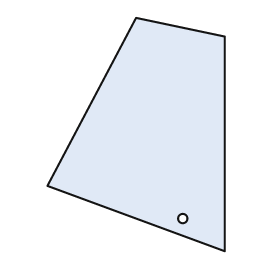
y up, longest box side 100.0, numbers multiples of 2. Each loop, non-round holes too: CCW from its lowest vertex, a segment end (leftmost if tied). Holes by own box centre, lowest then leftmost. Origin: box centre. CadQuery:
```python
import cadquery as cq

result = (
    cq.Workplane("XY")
    .moveTo(38.0, -50.0)
    .lineTo(38.0, 42.0)
    .lineTo(0.0, 50.0)
    .lineTo(-38.0, -22.0)
    .close()
    .moveTo(20.0, -36.0)
    .circle(2.0)
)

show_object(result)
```